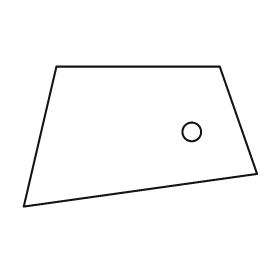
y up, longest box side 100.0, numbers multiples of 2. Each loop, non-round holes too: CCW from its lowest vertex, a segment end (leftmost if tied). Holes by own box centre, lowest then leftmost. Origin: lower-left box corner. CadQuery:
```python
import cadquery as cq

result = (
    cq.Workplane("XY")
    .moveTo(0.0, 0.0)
    .lineTo(100.0, 14.0)
    .lineTo(84.0, 60.0)
    .lineTo(14.0, 60.0)
    .close()
    .moveTo(72.0, 32.0)
    .circle(4.0)
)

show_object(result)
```